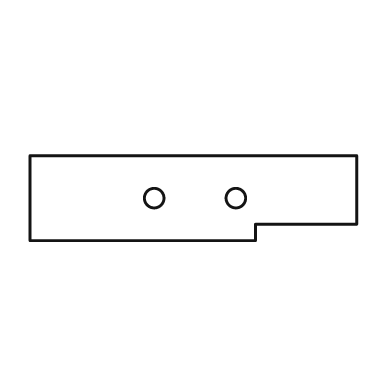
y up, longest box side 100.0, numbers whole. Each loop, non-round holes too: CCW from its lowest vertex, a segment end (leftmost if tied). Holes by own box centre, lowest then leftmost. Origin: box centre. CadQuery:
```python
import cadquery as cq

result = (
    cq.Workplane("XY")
    .moveTo(-50.0, -13.0)
    .lineTo(19.0, -13.0)
    .lineTo(19.0, -8.0)
    .lineTo(50.0, -8.0)
    .lineTo(50.0, 13.0)
    .lineTo(-50.0, 13.0)
    .close()
    .moveTo(-12.0, 0.0)
    .circle(3.0)
    .moveTo(13.0, 0.0)
    .circle(3.0)
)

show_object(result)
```